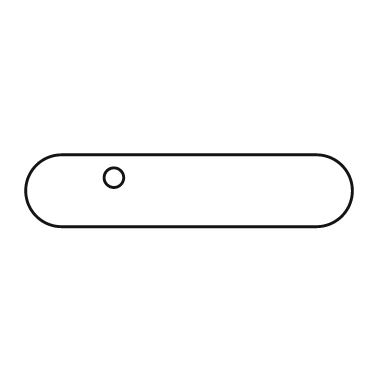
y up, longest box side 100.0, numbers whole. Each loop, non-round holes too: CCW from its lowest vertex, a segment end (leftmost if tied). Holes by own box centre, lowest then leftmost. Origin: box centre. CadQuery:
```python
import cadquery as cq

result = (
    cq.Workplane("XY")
    .moveTo(-39.0, -11.0)
    .lineTo(39.0, -11.0)
    .threePointArc((50.0, 0.0), (39.0, 11.0))
    .lineTo(-39.0, 11.0)
    .threePointArc((-50.0, 0.0), (-39.0, -11.0))
    .close()
    .moveTo(-23.0, 4.0)
    .circle(3.0)
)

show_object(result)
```